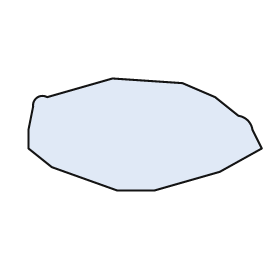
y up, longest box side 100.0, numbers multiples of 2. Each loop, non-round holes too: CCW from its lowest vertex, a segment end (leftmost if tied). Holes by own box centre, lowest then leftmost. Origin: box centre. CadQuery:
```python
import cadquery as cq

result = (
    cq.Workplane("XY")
    .moveTo(-12.0, -24.0)
    .lineTo(4.0, -24.0)
    .lineTo(32.0, -16.0)
    .lineTo(50.0, -6.0)
    .lineTo(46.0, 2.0)
    .threePointArc((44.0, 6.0), (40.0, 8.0))
    .lineTo(30.0, 16.0)
    .lineTo(16.0, 22.0)
    .lineTo(-14.0, 24.0)
    .lineTo(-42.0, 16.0)
    .threePointArc((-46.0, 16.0), (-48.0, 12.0))
    .lineTo(-50.0, 2.0)
    .lineTo(-50.0, -6.0)
    .lineTo(-40.0, -14.0)
    .close()
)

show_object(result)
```